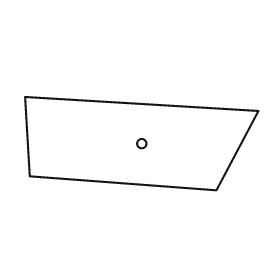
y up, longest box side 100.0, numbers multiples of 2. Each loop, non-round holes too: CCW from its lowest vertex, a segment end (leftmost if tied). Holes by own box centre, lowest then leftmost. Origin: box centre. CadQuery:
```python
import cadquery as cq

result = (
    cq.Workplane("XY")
    .moveTo(32.0, -20.0)
    .lineTo(50.0, 14.0)
    .lineTo(-50.0, 20.0)
    .lineTo(-48.0, -14.0)
    .close()
    .moveTo(0.0, 0.0)
    .circle(2.0)
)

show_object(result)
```